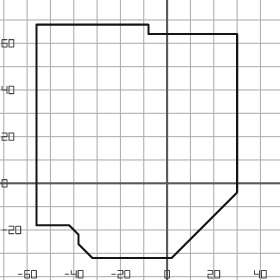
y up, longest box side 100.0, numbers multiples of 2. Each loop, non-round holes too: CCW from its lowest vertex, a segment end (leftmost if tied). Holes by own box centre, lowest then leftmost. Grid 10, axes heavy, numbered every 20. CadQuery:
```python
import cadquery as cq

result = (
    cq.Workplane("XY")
    .moveTo(-32.0, -32.0)
    .lineTo(2.0, -32.0)
    .lineTo(30.0, -4.0)
    .lineTo(30.0, 64.0)
    .lineTo(-8.0, 64.0)
    .lineTo(-8.0, 68.0)
    .lineTo(-56.0, 68.0)
    .lineTo(-56.0, -18.0)
    .lineTo(-42.0, -18.0)
    .lineTo(-38.0, -22.0)
    .lineTo(-38.0, -26.0)
    .close()
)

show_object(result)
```